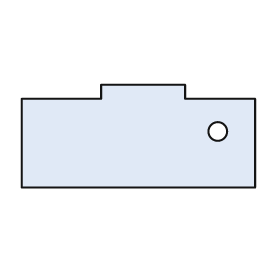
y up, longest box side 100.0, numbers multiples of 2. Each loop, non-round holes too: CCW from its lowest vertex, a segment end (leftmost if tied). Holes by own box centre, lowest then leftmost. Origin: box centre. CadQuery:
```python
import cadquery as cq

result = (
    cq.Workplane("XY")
    .moveTo(-50.0, -22.0)
    .lineTo(50.0, -22.0)
    .lineTo(50.0, 16.0)
    .lineTo(20.0, 16.0)
    .lineTo(20.0, 22.0)
    .lineTo(-16.0, 22.0)
    .lineTo(-16.0, 16.0)
    .lineTo(-50.0, 16.0)
    .close()
    .moveTo(34.0, 2.0)
    .circle(4.0)
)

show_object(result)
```